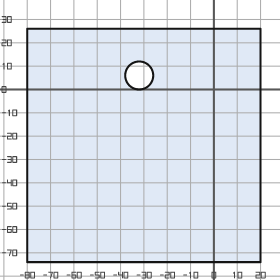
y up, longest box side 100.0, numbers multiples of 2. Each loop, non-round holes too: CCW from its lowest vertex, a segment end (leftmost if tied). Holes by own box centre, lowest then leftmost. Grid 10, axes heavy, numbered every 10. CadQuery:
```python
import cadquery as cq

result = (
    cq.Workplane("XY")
    .moveTo(-80.0, -74.0)
    .lineTo(20.0, -74.0)
    .lineTo(20.0, 26.0)
    .lineTo(-80.0, 26.0)
    .close()
    .moveTo(-32.0, 6.0)
    .circle(6.0)
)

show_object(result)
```